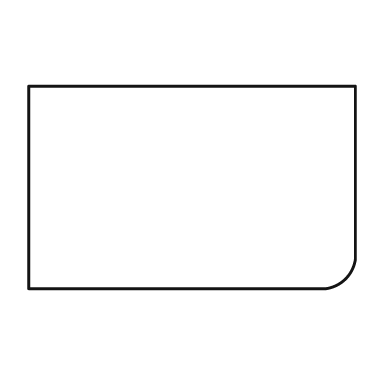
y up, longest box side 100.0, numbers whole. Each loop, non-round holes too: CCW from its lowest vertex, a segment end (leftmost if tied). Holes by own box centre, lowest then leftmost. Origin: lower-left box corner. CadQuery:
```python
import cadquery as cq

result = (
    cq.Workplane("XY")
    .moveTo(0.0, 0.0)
    .lineTo(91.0, 0.0)
    .threePointArc((97.0, 3.0), (100.0, 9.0))
    .lineTo(100.0, 62.0)
    .lineTo(0.0, 62.0)
    .close()
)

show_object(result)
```